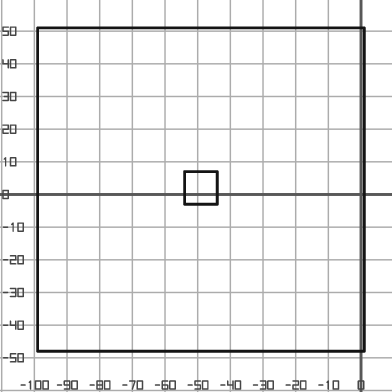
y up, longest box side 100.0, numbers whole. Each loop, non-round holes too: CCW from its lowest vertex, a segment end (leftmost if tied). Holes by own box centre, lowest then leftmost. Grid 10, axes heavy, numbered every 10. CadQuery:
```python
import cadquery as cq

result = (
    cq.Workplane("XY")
    .moveTo(-99.0, -48.0)
    .lineTo(1.0, -48.0)
    .lineTo(1.0, 51.0)
    .lineTo(-99.0, 51.0)
    .close()
    .moveTo(-54.0, -3.0)
    .lineTo(-44.0, -3.0)
    .lineTo(-44.0, 7.0)
    .lineTo(-54.0, 7.0)
    .close()
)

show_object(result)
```